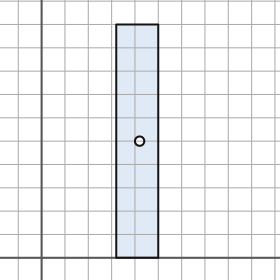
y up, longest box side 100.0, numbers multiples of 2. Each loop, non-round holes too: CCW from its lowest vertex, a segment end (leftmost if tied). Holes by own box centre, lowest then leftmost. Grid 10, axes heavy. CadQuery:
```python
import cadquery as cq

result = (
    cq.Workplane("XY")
    .moveTo(32.0, 0.0)
    .lineTo(50.0, 0.0)
    .lineTo(50.0, 100.0)
    .lineTo(32.0, 100.0)
    .close()
    .moveTo(42.0, 50.0)
    .circle(2.0)
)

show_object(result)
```